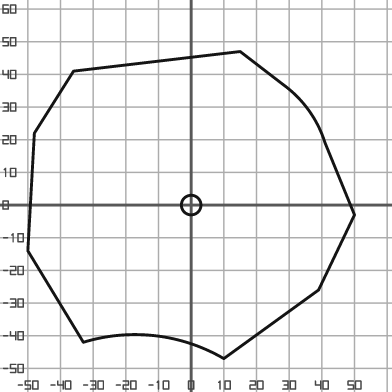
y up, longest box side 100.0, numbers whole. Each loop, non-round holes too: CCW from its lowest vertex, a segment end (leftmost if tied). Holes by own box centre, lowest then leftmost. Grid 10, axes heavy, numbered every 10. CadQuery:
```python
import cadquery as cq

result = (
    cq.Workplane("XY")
    .moveTo(10.0, -47.0)
    .lineTo(39.0, -26.0)
    .lineTo(50.0, -3.0)
    .lineTo(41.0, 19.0)
    .threePointArc((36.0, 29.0), (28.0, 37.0))
    .lineTo(15.0, 47.0)
    .lineTo(-36.0, 41.0)
    .lineTo(-48.0, 22.0)
    .lineTo(-50.0, -14.0)
    .lineTo(-33.0, -42.0)
    .threePointArc((-11.0, -40.0), (10.0, -47.0))
    .close()
    .moveTo(0.0, 0.0)
    .circle(3.0)
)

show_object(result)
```